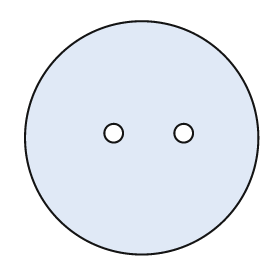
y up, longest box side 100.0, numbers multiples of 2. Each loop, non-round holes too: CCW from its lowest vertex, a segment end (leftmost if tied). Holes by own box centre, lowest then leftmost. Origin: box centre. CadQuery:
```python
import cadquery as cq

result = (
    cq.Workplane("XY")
    .moveTo(0.0, 0.0)
    .circle(50.0)
    .moveTo(-12.0, 2.0)
    .circle(4.0)
    .moveTo(18.0, 2.0)
    .circle(4.0)
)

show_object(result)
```